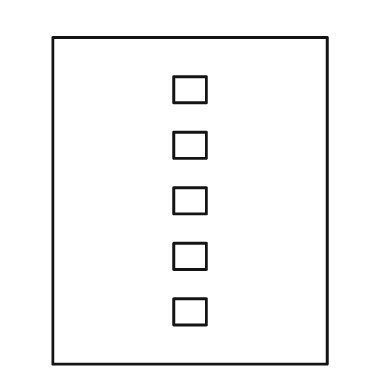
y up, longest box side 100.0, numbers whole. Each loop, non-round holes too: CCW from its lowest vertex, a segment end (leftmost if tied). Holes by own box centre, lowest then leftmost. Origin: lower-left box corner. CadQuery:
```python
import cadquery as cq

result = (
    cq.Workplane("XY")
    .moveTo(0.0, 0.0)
    .lineTo(84.0, 0.0)
    .lineTo(84.0, 100.0)
    .lineTo(0.0, 100.0)
    .close()
    .moveTo(37.0, 12.0)
    .lineTo(47.0, 12.0)
    .lineTo(47.0, 20.0)
    .lineTo(37.0, 20.0)
    .close()
    .moveTo(37.0, 29.0)
    .lineTo(47.0, 29.0)
    .lineTo(47.0, 37.0)
    .lineTo(37.0, 37.0)
    .close()
    .moveTo(37.0, 46.0)
    .lineTo(47.0, 46.0)
    .lineTo(47.0, 54.0)
    .lineTo(37.0, 54.0)
    .close()
    .moveTo(37.0, 63.0)
    .lineTo(47.0, 63.0)
    .lineTo(47.0, 71.0)
    .lineTo(37.0, 71.0)
    .close()
    .moveTo(37.0, 80.0)
    .lineTo(47.0, 80.0)
    .lineTo(47.0, 88.0)
    .lineTo(37.0, 88.0)
    .close()
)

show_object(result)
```